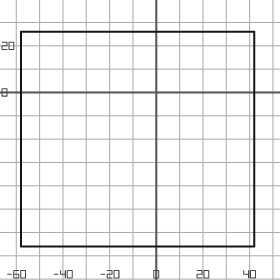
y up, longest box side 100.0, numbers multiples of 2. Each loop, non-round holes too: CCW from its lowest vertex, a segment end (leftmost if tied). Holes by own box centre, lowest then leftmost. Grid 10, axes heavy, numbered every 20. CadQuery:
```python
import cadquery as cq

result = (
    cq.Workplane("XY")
    .moveTo(-58.0, -66.0)
    .lineTo(42.0, -66.0)
    .lineTo(42.0, 26.0)
    .lineTo(-58.0, 26.0)
    .close()
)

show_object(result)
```